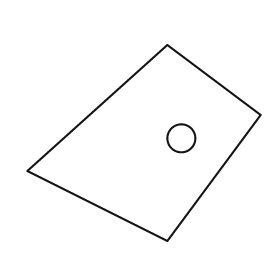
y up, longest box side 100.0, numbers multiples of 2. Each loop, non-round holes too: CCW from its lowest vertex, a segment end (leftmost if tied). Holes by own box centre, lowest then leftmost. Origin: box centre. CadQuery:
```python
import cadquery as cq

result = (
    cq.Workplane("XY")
    .moveTo(10.0, -42.0)
    .lineTo(50.0, 12.0)
    .lineTo(10.0, 42.0)
    .lineTo(-50.0, -12.0)
    .close()
    .moveTo(16.0, 2.0)
    .circle(6.0)
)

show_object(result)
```